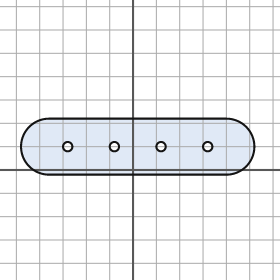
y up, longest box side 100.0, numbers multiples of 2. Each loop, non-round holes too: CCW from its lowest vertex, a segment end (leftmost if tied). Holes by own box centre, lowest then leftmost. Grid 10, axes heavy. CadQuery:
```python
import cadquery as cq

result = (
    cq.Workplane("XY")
    .moveTo(-36.0, -2.0)
    .lineTo(40.0, -2.0)
    .threePointArc((52.0, 10.0), (40.0, 22.0))
    .lineTo(-36.0, 22.0)
    .threePointArc((-48.0, 10.0), (-36.0, -2.0))
    .close()
    .moveTo(-28.0, 10.0)
    .circle(2.0)
    .moveTo(-8.0, 10.0)
    .circle(2.0)
    .moveTo(12.0, 10.0)
    .circle(2.0)
    .moveTo(32.0, 10.0)
    .circle(2.0)
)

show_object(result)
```